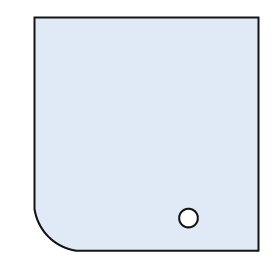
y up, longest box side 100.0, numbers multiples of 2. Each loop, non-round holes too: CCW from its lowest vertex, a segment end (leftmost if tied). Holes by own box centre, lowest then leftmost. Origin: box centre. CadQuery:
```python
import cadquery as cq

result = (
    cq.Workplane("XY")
    .moveTo(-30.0, -50.0)
    .lineTo(48.0, -50.0)
    .lineTo(48.0, 50.0)
    .lineTo(-48.0, 50.0)
    .lineTo(-48.0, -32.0)
    .threePointArc((-42.0, -44.0), (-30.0, -50.0))
    .close()
    .moveTo(18.0, -36.0)
    .circle(4.0)
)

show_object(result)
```